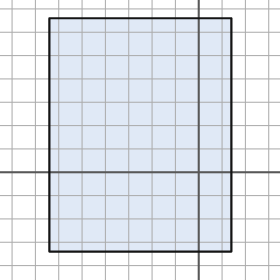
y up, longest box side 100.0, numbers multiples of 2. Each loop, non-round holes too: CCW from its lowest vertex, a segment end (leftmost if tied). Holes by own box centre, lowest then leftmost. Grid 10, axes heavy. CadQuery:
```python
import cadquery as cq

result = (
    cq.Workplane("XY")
    .moveTo(-64.0, -34.0)
    .lineTo(14.0, -34.0)
    .lineTo(14.0, 66.0)
    .lineTo(-64.0, 66.0)
    .close()
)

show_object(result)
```